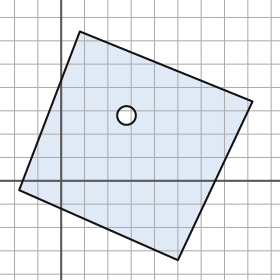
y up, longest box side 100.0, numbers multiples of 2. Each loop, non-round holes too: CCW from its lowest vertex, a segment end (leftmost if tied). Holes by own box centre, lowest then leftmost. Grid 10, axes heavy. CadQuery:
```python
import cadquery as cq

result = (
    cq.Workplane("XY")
    .moveTo(50.0, -34.0)
    .lineTo(82.0, 34.0)
    .lineTo(8.0, 64.0)
    .lineTo(-18.0, -4.0)
    .close()
    .moveTo(28.0, 28.0)
    .circle(4.0)
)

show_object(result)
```